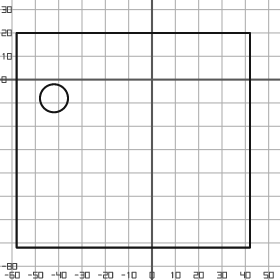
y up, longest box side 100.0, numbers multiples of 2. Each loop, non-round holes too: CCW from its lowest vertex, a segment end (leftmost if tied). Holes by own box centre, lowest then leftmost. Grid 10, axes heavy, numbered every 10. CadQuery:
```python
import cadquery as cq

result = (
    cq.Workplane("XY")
    .moveTo(-58.0, -72.0)
    .lineTo(42.0, -72.0)
    .lineTo(42.0, 20.0)
    .lineTo(-58.0, 20.0)
    .close()
    .moveTo(-42.0, -8.0)
    .circle(6.0)
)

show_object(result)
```